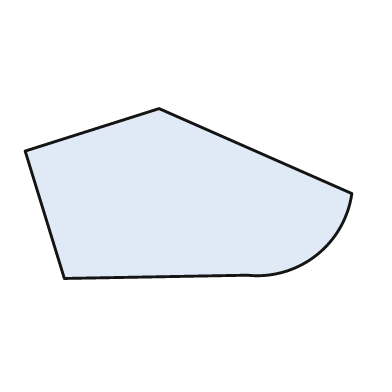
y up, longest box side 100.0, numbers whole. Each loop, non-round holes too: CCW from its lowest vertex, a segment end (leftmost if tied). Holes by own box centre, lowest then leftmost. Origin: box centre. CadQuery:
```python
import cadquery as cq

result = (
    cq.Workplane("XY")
    .moveTo(-38.0, -26.0)
    .lineTo(18.0, -25.0)
    .threePointArc((39.0, -19.0), (50.0, 0.0))
    .lineTo(-9.0, 26.0)
    .lineTo(-50.0, 13.0)
    .close()
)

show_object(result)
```